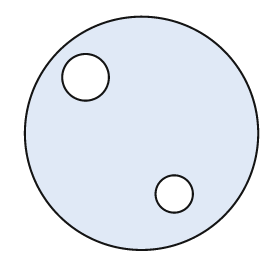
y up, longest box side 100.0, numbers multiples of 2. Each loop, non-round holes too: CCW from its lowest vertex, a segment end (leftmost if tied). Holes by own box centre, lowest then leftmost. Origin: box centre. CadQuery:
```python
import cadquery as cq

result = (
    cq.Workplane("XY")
    .moveTo(0.0, 0.0)
    .circle(50.0)
    .moveTo(14.0, -26.0)
    .circle(8.0)
    .moveTo(-24.0, 24.0)
    .circle(10.0)
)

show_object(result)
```